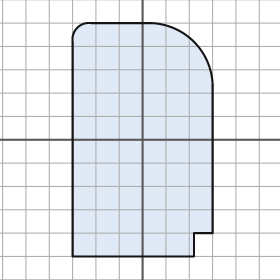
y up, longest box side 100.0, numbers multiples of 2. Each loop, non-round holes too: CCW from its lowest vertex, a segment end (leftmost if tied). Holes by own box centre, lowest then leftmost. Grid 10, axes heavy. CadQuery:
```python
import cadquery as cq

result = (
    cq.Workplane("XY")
    .moveTo(-30.0, -50.0)
    .lineTo(22.0, -50.0)
    .lineTo(22.0, -40.0)
    .lineTo(30.0, -40.0)
    .lineTo(30.0, 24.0)
    .threePointArc((22.0, 42.0), (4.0, 50.0))
    .lineTo(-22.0, 50.0)
    .threePointArc((-28.0, 48.0), (-30.0, 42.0))
    .close()
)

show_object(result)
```